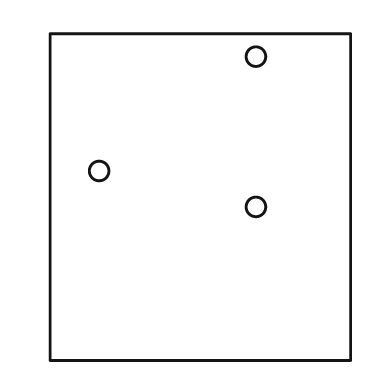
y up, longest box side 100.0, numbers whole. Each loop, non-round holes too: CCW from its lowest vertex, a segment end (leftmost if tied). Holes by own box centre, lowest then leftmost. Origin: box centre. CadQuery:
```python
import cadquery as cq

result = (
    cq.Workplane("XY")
    .moveTo(-46.0, -50.0)
    .lineTo(46.0, -50.0)
    .lineTo(46.0, 50.0)
    .lineTo(-46.0, 50.0)
    .close()
    .moveTo(17.0, -3.0)
    .circle(3.0)
    .moveTo(-31.0, 8.0)
    .circle(3.0)
    .moveTo(17.0, 43.0)
    .circle(3.0)
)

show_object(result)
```